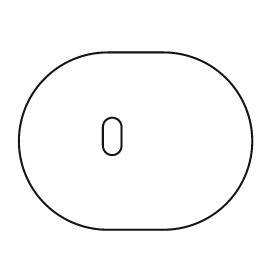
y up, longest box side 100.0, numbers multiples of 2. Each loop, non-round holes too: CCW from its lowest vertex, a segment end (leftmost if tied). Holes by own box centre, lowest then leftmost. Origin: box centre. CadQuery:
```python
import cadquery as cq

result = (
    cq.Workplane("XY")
    .moveTo(-12.0, -38.0)
    .lineTo(12.0, -38.0)
    .threePointArc((50.0, 0.0), (12.0, 38.0))
    .lineTo(-12.0, 38.0)
    .threePointArc((-50.0, 0.0), (-12.0, -38.0))
    .close()
    .moveTo(-14.0, -2.0)
    .threePointArc((-10.0, -6.0), (-6.0, -2.0))
    .lineTo(-6.0, 6.0)
    .threePointArc((-10.0, 10.0), (-14.0, 6.0))
    .close()
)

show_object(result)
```